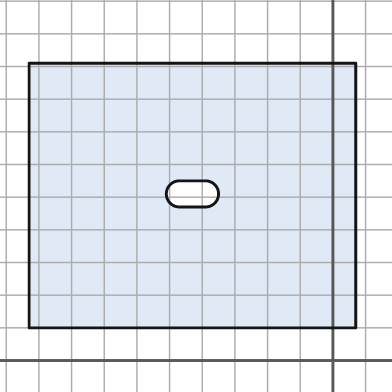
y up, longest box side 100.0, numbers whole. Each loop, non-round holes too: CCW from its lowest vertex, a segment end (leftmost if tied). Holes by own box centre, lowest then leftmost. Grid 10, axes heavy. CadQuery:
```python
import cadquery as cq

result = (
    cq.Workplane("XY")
    .moveTo(-93.0, 10.0)
    .lineTo(7.0, 10.0)
    .lineTo(7.0, 91.0)
    .lineTo(-93.0, 91.0)
    .close()
    .moveTo(-47.0, 47.0)
    .lineTo(-39.0, 47.0)
    .threePointArc((-35.0, 51.0), (-39.0, 55.0))
    .lineTo(-47.0, 55.0)
    .threePointArc((-51.0, 51.0), (-47.0, 47.0))
    .close()
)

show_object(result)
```